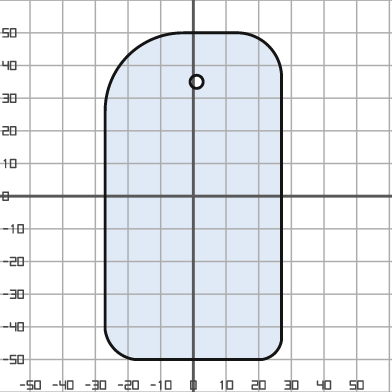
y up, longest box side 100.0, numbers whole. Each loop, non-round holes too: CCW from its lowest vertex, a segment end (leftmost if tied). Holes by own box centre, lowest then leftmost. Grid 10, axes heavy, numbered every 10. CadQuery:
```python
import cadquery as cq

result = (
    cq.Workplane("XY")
    .moveTo(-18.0, -50.0)
    .lineTo(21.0, -50.0)
    .threePointArc((25.0, -48.0), (27.0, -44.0))
    .lineTo(27.0, 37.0)
    .threePointArc((23.0, 46.0), (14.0, 50.0))
    .lineTo(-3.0, 50.0)
    .threePointArc((-20.0, 43.0), (-27.0, 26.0))
    .lineTo(-27.0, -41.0)
    .threePointArc((-24.0, -47.0), (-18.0, -50.0))
    .close()
    .moveTo(1.0, 35.0)
    .circle(2.0)
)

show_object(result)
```